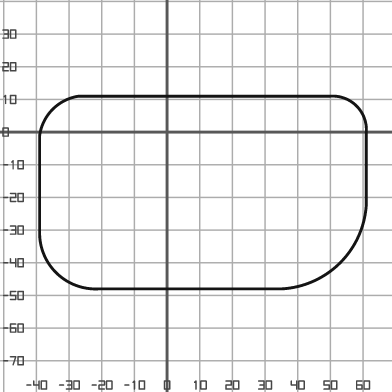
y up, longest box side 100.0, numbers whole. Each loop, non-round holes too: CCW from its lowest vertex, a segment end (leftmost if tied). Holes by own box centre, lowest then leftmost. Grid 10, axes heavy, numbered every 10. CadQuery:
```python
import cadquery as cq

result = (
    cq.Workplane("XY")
    .moveTo(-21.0, -48.0)
    .lineTo(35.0, -48.0)
    .threePointArc((53.0, -40.0), (61.0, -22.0))
    .lineTo(61.0, 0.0)
    .threePointArc((58.0, 8.0), (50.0, 11.0))
    .lineTo(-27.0, 11.0)
    .threePointArc((-35.0, 7.0), (-39.0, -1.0))
    .lineTo(-39.0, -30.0)
    .threePointArc((-34.0, -43.0), (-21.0, -48.0))
    .close()
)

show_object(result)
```